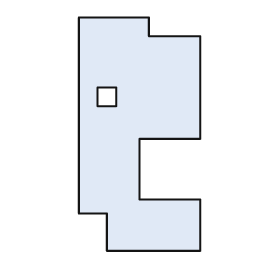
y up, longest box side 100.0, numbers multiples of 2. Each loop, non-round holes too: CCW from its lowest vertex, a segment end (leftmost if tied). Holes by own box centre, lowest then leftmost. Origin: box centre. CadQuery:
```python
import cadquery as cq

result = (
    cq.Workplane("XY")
    .moveTo(-14.0, -50.0)
    .lineTo(26.0, -50.0)
    .lineTo(26.0, -28.0)
    .lineTo(0.0, -28.0)
    .lineTo(0.0, -2.0)
    .lineTo(26.0, -2.0)
    .lineTo(26.0, 42.0)
    .lineTo(4.0, 42.0)
    .lineTo(4.0, 50.0)
    .lineTo(-26.0, 50.0)
    .lineTo(-26.0, -34.0)
    .lineTo(-14.0, -34.0)
    .close()
    .moveTo(-18.0, 12.0)
    .lineTo(-10.0, 12.0)
    .lineTo(-10.0, 20.0)
    .lineTo(-18.0, 20.0)
    .close()
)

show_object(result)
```